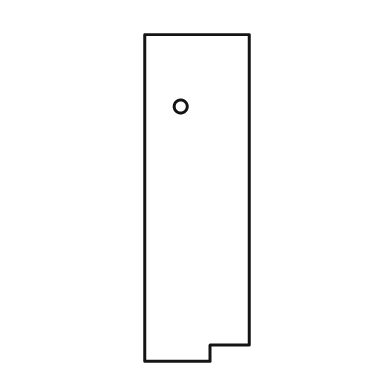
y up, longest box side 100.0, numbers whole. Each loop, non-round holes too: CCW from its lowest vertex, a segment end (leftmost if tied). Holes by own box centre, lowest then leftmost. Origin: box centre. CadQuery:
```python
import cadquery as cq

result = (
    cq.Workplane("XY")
    .moveTo(-16.0, -50.0)
    .lineTo(4.0, -50.0)
    .lineTo(4.0, -45.0)
    .lineTo(16.0, -45.0)
    .lineTo(16.0, 50.0)
    .lineTo(-16.0, 50.0)
    .close()
    .moveTo(-5.0, 28.0)
    .circle(2.0)
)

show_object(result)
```